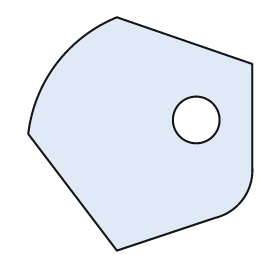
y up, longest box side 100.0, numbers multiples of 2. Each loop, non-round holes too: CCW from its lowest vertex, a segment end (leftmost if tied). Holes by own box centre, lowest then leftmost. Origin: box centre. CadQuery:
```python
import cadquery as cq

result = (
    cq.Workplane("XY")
    .moveTo(-10.0, -50.0)
    .lineTo(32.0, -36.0)
    .threePointArc((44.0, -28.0), (48.0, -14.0))
    .lineTo(48.0, 30.0)
    .lineTo(-10.0, 50.0)
    .threePointArc((-36.0, 30.0), (-48.0, 0.0))
    .close()
    .moveTo(24.0, 6.0)
    .circle(10.0)
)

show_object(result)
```